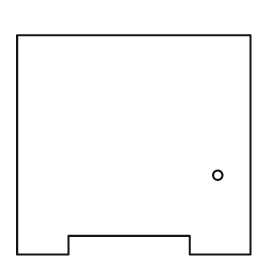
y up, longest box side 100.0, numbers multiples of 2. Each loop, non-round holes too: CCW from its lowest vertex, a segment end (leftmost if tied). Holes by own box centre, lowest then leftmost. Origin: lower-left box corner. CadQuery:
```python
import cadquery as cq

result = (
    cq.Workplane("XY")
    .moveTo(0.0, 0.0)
    .lineTo(22.0, 0.0)
    .lineTo(22.0, 8.0)
    .lineTo(74.0, 8.0)
    .lineTo(74.0, 0.0)
    .lineTo(100.0, 0.0)
    .lineTo(100.0, 94.0)
    .lineTo(0.0, 94.0)
    .close()
    .moveTo(86.0, 34.0)
    .circle(2.0)
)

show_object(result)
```